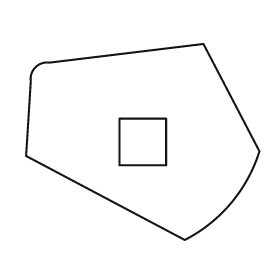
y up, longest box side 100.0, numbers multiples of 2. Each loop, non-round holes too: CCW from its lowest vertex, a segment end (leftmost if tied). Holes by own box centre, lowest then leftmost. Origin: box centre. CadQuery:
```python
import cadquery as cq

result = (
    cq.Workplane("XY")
    .moveTo(18.0, -42.0)
    .threePointArc((38.0, -26.0), (50.0, -4.0))
    .lineTo(26.0, 42.0)
    .lineTo(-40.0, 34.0)
    .threePointArc((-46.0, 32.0), (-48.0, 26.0))
    .lineTo(-50.0, -6.0)
    .close()
    .moveTo(-10.0, -10.0)
    .lineTo(10.0, -10.0)
    .lineTo(10.0, 10.0)
    .lineTo(-10.0, 10.0)
    .close()
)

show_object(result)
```